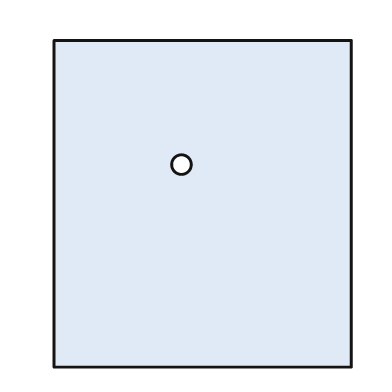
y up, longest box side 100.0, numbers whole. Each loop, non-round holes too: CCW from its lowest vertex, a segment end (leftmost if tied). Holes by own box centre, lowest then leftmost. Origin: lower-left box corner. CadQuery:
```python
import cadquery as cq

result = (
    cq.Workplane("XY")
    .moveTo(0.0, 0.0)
    .lineTo(91.0, 0.0)
    .lineTo(91.0, 100.0)
    .lineTo(0.0, 100.0)
    .close()
    .moveTo(39.0, 62.0)
    .circle(3.0)
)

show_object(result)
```